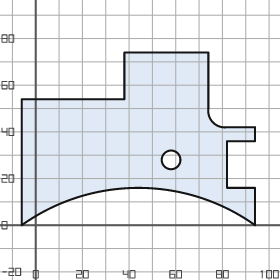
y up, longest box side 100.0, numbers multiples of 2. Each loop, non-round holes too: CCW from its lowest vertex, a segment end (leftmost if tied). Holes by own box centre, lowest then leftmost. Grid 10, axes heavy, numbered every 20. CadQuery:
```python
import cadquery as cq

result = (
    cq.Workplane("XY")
    .moveTo(-6.0, 0.0)
    .threePointArc((44.0, 16.0), (94.0, 0.0))
    .lineTo(94.0, 16.0)
    .lineTo(82.0, 16.0)
    .lineTo(82.0, 36.0)
    .lineTo(94.0, 36.0)
    .lineTo(94.0, 42.0)
    .lineTo(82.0, 42.0)
    .threePointArc((76.0, 44.0), (74.0, 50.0))
    .lineTo(74.0, 74.0)
    .lineTo(38.0, 74.0)
    .lineTo(38.0, 54.0)
    .lineTo(-6.0, 54.0)
    .close()
    .moveTo(58.0, 28.0)
    .circle(4.0)
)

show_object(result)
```